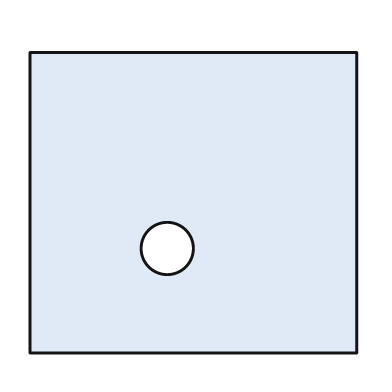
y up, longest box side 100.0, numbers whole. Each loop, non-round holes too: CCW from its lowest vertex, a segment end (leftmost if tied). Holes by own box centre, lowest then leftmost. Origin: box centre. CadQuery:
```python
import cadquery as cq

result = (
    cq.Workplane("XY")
    .moveTo(-50.0, -46.0)
    .lineTo(50.0, -46.0)
    .lineTo(50.0, 46.0)
    .lineTo(-50.0, 46.0)
    .close()
    .moveTo(-8.0, -14.0)
    .circle(8.0)
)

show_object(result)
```